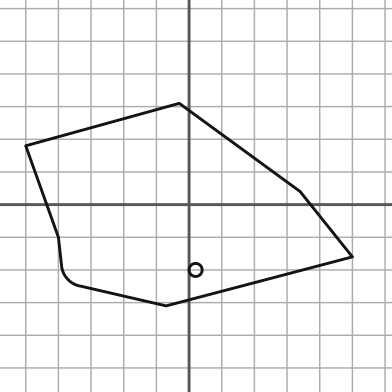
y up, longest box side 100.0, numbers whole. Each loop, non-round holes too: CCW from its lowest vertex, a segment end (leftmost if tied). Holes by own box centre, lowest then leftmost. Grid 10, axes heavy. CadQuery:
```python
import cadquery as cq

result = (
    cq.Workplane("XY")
    .moveTo(-7.0, -31.0)
    .lineTo(50.0, -16.0)
    .lineTo(34.0, 4.0)
    .lineTo(-3.0, 31.0)
    .lineTo(-50.0, 18.0)
    .lineTo(-40.0, -10.0)
    .lineTo(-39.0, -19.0)
    .threePointArc((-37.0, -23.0), (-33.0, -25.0))
    .close()
    .moveTo(2.0, -20.0)
    .circle(2.0)
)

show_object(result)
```